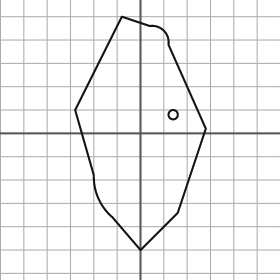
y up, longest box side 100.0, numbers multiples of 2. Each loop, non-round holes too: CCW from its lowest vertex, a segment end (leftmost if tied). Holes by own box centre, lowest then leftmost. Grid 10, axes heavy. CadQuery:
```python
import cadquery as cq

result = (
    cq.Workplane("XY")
    .moveTo(0.0, -50.0)
    .lineTo(16.0, -34.0)
    .lineTo(28.0, 2.0)
    .lineTo(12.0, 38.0)
    .threePointArc((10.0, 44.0), (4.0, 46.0))
    .lineTo(-8.0, 50.0)
    .lineTo(-28.0, 10.0)
    .lineTo(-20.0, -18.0)
    .threePointArc((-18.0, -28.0), (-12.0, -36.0))
    .close()
    .moveTo(14.0, 8.0)
    .circle(2.0)
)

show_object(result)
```